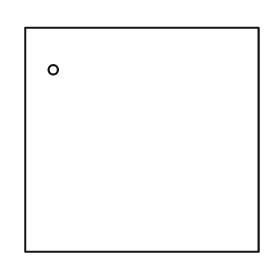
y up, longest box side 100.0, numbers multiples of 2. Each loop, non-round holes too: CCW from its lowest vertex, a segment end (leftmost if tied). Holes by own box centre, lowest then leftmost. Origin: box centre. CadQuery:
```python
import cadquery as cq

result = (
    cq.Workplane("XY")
    .moveTo(-50.0, -48.0)
    .lineTo(50.0, -48.0)
    .lineTo(50.0, 48.0)
    .lineTo(-50.0, 48.0)
    .close()
    .moveTo(-38.0, 30.0)
    .circle(2.0)
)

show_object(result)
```